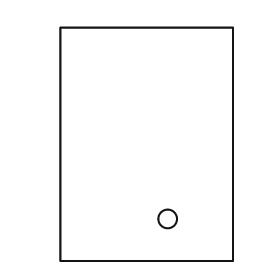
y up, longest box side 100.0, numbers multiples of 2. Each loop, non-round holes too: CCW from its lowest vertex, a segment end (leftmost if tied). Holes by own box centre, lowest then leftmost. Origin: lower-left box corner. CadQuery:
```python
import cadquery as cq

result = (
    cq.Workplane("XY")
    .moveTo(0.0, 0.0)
    .lineTo(74.0, 0.0)
    .lineTo(74.0, 100.0)
    .lineTo(0.0, 100.0)
    .close()
    .moveTo(46.0, 18.0)
    .circle(4.0)
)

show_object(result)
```